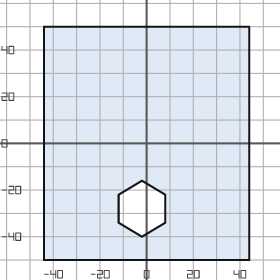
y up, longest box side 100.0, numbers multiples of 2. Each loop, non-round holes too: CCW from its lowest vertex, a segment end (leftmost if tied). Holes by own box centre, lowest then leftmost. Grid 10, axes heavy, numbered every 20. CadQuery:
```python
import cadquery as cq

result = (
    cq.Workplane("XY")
    .moveTo(-44.0, -50.0)
    .lineTo(44.0, -50.0)
    .lineTo(44.0, 50.0)
    .lineTo(-44.0, 50.0)
    .close()
    .moveTo(-2.0, -40.0)
    .lineTo(8.0, -34.0)
    .lineTo(8.0, -22.0)
    .lineTo(-2.0, -16.0)
    .lineTo(-12.0, -22.0)
    .lineTo(-12.0, -34.0)
    .close()
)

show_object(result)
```